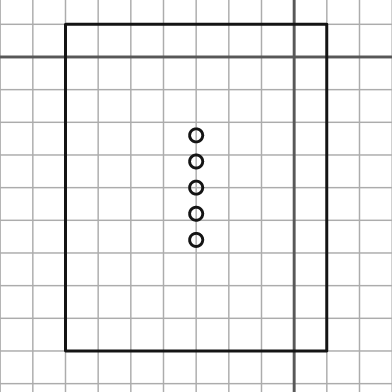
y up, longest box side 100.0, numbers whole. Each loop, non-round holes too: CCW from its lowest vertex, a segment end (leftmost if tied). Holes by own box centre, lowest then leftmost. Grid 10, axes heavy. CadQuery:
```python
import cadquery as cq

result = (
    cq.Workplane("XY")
    .moveTo(-70.0, -90.0)
    .lineTo(10.0, -90.0)
    .lineTo(10.0, 10.0)
    .lineTo(-70.0, 10.0)
    .close()
    .moveTo(-30.0, -56.0)
    .circle(2.0)
    .moveTo(-30.0, -48.0)
    .circle(2.0)
    .moveTo(-30.0, -40.0)
    .circle(2.0)
    .moveTo(-30.0, -32.0)
    .circle(2.0)
    .moveTo(-30.0, -24.0)
    .circle(2.0)
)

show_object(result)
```